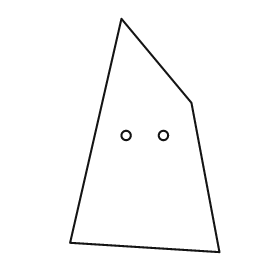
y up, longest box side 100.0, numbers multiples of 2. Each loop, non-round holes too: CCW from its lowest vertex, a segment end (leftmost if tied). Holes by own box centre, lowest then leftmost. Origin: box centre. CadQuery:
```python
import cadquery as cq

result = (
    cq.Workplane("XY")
    .moveTo(32.0, -50.0)
    .lineTo(20.0, 14.0)
    .lineTo(-10.0, 50.0)
    .lineTo(-32.0, -46.0)
    .close()
    .moveTo(-8.0, 0.0)
    .circle(2.0)
    .moveTo(8.0, 0.0)
    .circle(2.0)
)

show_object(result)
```